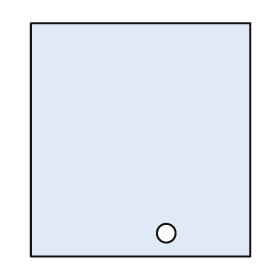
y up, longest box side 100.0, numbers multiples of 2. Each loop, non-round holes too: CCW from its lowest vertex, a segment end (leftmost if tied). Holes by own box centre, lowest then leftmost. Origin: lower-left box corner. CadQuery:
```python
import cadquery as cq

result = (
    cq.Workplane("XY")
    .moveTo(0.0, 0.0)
    .lineTo(94.0, 0.0)
    .lineTo(94.0, 100.0)
    .lineTo(0.0, 100.0)
    .close()
    .moveTo(58.0, 10.0)
    .circle(4.0)
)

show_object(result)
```